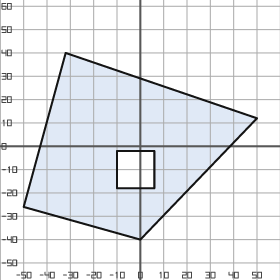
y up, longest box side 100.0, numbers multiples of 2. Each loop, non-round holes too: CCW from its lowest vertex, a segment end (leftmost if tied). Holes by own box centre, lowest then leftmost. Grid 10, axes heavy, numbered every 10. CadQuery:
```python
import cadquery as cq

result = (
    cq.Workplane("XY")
    .moveTo(0.0, -40.0)
    .lineTo(50.0, 12.0)
    .lineTo(-32.0, 40.0)
    .lineTo(-50.0, -26.0)
    .close()
    .moveTo(-10.0, -18.0)
    .lineTo(6.0, -18.0)
    .lineTo(6.0, -2.0)
    .lineTo(-10.0, -2.0)
    .close()
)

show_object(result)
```